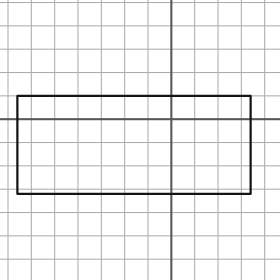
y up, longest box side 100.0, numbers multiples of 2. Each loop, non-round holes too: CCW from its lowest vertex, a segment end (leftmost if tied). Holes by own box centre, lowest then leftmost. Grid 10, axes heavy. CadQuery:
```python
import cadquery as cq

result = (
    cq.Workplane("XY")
    .moveTo(-66.0, -32.0)
    .lineTo(34.0, -32.0)
    .lineTo(34.0, 10.0)
    .lineTo(-66.0, 10.0)
    .close()
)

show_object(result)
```